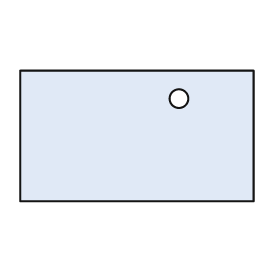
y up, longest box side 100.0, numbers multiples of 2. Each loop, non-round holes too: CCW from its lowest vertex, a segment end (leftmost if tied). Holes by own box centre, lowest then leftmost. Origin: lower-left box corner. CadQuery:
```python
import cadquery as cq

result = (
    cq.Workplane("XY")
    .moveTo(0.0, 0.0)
    .lineTo(100.0, 0.0)
    .lineTo(100.0, 56.0)
    .lineTo(0.0, 56.0)
    .close()
    .moveTo(68.0, 44.0)
    .circle(4.0)
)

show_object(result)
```